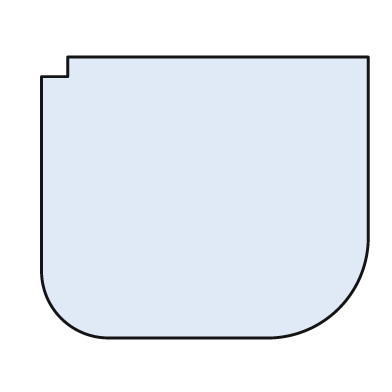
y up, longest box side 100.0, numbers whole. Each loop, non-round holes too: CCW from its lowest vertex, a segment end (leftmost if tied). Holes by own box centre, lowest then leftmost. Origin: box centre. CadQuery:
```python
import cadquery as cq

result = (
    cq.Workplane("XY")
    .moveTo(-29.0, -43.0)
    .lineTo(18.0, -43.0)
    .threePointArc((41.0, -34.0), (50.0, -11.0))
    .lineTo(50.0, 43.0)
    .lineTo(-42.0, 43.0)
    .lineTo(-42.0, 37.0)
    .lineTo(-50.0, 37.0)
    .lineTo(-50.0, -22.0)
    .threePointArc((-44.0, -37.0), (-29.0, -43.0))
    .close()
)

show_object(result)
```